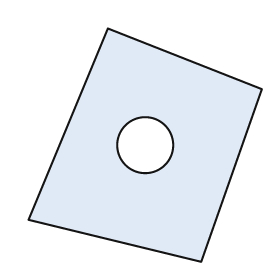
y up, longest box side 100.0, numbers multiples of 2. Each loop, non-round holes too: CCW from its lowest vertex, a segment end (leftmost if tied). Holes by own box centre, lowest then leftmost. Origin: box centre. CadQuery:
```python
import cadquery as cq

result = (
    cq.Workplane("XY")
    .moveTo(24.0, -50.0)
    .lineTo(50.0, 24.0)
    .lineTo(-16.0, 50.0)
    .lineTo(-50.0, -32.0)
    .close()
    .moveTo(0.0, 0.0)
    .circle(12.0)
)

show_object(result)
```